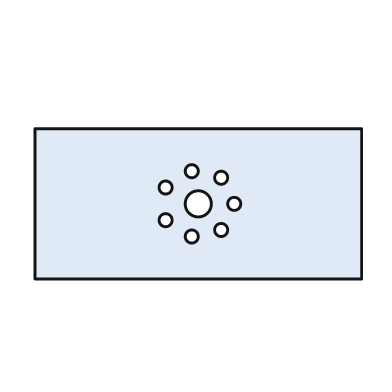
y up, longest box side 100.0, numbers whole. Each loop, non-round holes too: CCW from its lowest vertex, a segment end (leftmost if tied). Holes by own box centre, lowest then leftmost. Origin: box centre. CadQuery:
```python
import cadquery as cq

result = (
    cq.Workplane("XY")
    .moveTo(-50.0, -23.0)
    .lineTo(50.0, -23.0)
    .lineTo(50.0, 23.0)
    .lineTo(-50.0, 23.0)
    .close()
    .moveTo(-2.0, -10.0)
    .circle(2.0)
    .moveTo(7.0, -8.0)
    .circle(2.0)
    .moveTo(-10.0, -5.0)
    .circle(2.0)
    .moveTo(0.0, 0.0)
    .circle(4.0)
    .moveTo(11.0, 0.0)
    .circle(2.0)
    .moveTo(-10.0, 5.0)
    .circle(2.0)
    .moveTo(7.0, 8.0)
    .circle(2.0)
    .moveTo(-2.0, 10.0)
    .circle(2.0)
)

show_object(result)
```